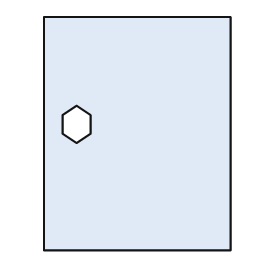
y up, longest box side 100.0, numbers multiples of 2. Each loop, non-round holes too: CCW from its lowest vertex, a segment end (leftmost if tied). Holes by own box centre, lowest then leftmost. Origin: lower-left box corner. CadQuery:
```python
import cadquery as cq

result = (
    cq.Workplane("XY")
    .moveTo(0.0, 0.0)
    .lineTo(80.0, 0.0)
    .lineTo(80.0, 100.0)
    .lineTo(0.0, 100.0)
    .close()
    .moveTo(14.0, 46.0)
    .lineTo(20.0, 50.0)
    .lineTo(20.0, 58.0)
    .lineTo(14.0, 62.0)
    .lineTo(8.0, 58.0)
    .lineTo(8.0, 50.0)
    .close()
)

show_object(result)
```